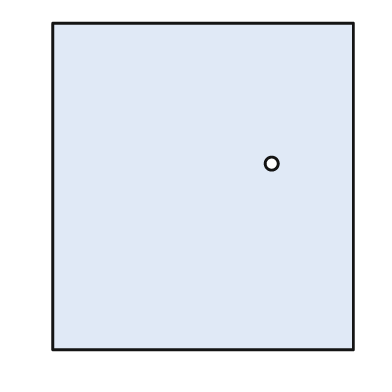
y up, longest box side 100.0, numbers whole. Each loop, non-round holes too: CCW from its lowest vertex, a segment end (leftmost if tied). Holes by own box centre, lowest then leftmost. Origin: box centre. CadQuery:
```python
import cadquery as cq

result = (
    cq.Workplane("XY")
    .moveTo(-46.0, -50.0)
    .lineTo(46.0, -50.0)
    .lineTo(46.0, 50.0)
    .lineTo(-46.0, 50.0)
    .close()
    .moveTo(21.0, 7.0)
    .circle(2.0)
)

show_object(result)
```